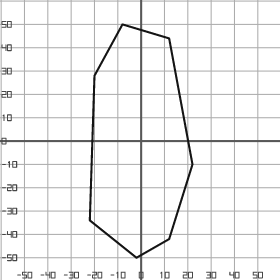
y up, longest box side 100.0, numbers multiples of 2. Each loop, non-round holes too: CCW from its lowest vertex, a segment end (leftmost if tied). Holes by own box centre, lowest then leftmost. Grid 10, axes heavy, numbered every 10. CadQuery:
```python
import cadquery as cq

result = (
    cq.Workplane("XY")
    .moveTo(-2.0, -50.0)
    .lineTo(12.0, -42.0)
    .lineTo(22.0, -10.0)
    .lineTo(12.0, 44.0)
    .lineTo(-8.0, 50.0)
    .lineTo(-20.0, 28.0)
    .lineTo(-22.0, -34.0)
    .close()
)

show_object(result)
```